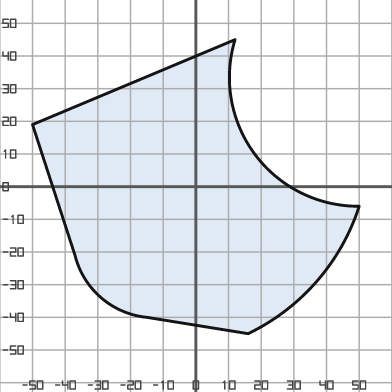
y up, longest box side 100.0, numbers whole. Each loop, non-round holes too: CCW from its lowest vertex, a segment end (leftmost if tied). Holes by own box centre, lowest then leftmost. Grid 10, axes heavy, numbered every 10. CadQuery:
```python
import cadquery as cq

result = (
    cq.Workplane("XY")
    .moveTo(16.0, -45.0)
    .threePointArc((37.0, -29.0), (50.0, -6.0))
    .threePointArc((18.0, 10.0), (12.0, 45.0))
    .lineTo(-50.0, 19.0)
    .lineTo(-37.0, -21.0)
    .threePointArc((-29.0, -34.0), (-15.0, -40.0))
    .close()
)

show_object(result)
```